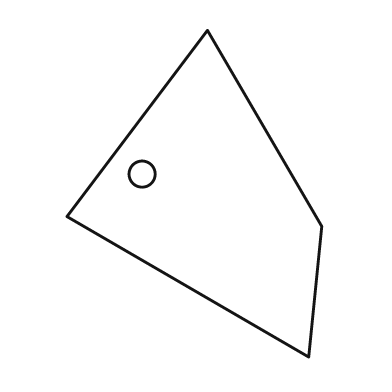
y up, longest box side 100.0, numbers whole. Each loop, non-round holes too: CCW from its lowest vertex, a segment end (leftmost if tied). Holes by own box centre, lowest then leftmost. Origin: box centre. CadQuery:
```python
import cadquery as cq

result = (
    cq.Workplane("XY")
    .moveTo(35.0, -50.0)
    .lineTo(39.0, -10.0)
    .lineTo(4.0, 50.0)
    .lineTo(-39.0, -7.0)
    .close()
    .moveTo(-16.0, 6.0)
    .circle(4.0)
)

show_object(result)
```